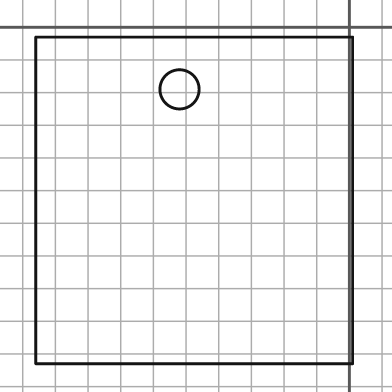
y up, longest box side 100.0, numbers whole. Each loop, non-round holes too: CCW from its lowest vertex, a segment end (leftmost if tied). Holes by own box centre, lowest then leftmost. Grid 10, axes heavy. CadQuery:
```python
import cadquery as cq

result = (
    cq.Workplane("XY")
    .moveTo(-96.0, -103.0)
    .lineTo(1.0, -103.0)
    .lineTo(1.0, -3.0)
    .lineTo(-96.0, -3.0)
    .close()
    .moveTo(-52.0, -19.0)
    .circle(6.0)
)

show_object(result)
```